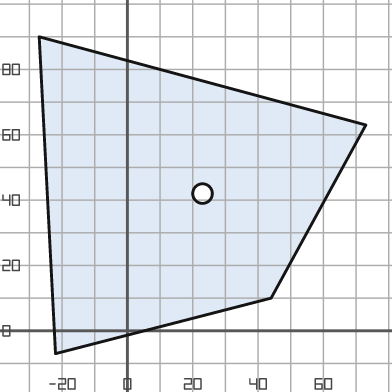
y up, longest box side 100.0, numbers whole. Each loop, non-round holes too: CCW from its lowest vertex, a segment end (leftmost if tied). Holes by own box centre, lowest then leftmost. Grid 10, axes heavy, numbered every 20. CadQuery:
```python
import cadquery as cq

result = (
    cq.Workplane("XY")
    .moveTo(-22.0, -7.0)
    .lineTo(44.0, 10.0)
    .lineTo(73.0, 63.0)
    .lineTo(-27.0, 90.0)
    .close()
    .moveTo(23.0, 42.0)
    .circle(3.0)
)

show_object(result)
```